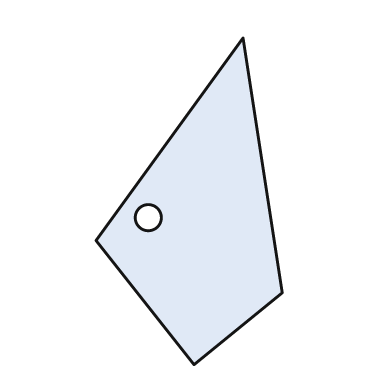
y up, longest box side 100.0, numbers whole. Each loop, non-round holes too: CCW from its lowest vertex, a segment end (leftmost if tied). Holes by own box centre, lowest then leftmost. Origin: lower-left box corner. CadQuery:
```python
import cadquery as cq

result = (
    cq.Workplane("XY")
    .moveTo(30.0, 0.0)
    .lineTo(57.0, 22.0)
    .lineTo(45.0, 100.0)
    .lineTo(0.0, 38.0)
    .close()
    .moveTo(16.0, 45.0)
    .circle(4.0)
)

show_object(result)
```